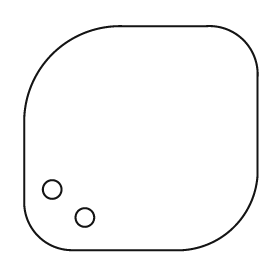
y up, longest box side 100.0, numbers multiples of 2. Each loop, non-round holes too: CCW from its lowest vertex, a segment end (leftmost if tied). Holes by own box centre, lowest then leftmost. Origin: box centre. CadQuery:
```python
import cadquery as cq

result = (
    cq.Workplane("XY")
    .moveTo(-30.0, -48.0)
    .lineTo(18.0, -48.0)
    .threePointArc((40.0, -38.0), (50.0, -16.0))
    .lineTo(50.0, 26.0)
    .threePointArc((44.0, 42.0), (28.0, 48.0))
    .lineTo(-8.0, 48.0)
    .threePointArc((-38.0, 36.0), (-50.0, 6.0))
    .lineTo(-50.0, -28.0)
    .threePointArc((-44.0, -42.0), (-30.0, -48.0))
    .close()
    .moveTo(-24.0, -34.0)
    .circle(4.0)
    .moveTo(-38.0, -22.0)
    .circle(4.0)
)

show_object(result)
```